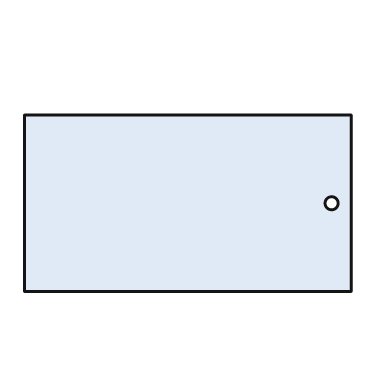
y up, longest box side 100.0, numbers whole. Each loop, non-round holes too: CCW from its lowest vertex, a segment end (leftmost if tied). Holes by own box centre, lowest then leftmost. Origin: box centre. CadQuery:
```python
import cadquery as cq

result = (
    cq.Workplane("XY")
    .moveTo(-50.0, -27.0)
    .lineTo(50.0, -27.0)
    .lineTo(50.0, 27.0)
    .lineTo(-50.0, 27.0)
    .close()
    .moveTo(44.0, 0.0)
    .circle(2.0)
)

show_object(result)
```